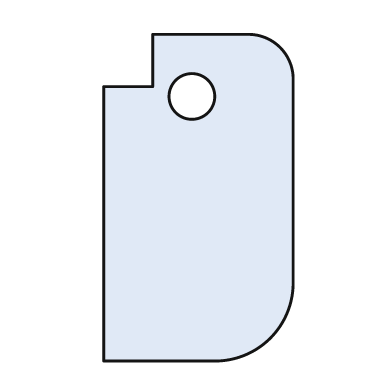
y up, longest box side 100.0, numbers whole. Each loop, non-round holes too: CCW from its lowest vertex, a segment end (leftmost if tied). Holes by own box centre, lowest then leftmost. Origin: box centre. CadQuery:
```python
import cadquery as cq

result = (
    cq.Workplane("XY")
    .moveTo(-29.0, -50.0)
    .lineTo(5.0, -50.0)
    .threePointArc((22.0, -43.0), (29.0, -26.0))
    .lineTo(29.0, 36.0)
    .threePointArc((25.0, 46.0), (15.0, 50.0))
    .lineTo(-14.0, 50.0)
    .lineTo(-14.0, 34.0)
    .lineTo(-29.0, 34.0)
    .close()
    .moveTo(-2.0, 31.0)
    .circle(7.0)
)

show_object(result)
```